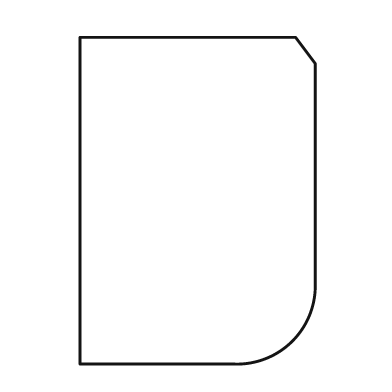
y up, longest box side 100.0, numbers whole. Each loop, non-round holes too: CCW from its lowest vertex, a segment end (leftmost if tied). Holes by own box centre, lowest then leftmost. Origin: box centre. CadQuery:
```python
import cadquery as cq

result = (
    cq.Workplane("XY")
    .moveTo(-36.0, -50.0)
    .lineTo(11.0, -50.0)
    .threePointArc((29.0, -43.0), (36.0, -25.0))
    .lineTo(36.0, 42.0)
    .lineTo(30.0, 50.0)
    .lineTo(-36.0, 50.0)
    .close()
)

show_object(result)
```